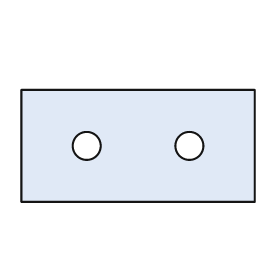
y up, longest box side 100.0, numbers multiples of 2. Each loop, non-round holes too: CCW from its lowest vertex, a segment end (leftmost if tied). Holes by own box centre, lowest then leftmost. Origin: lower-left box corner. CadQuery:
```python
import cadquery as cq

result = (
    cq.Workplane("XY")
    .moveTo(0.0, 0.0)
    .lineTo(100.0, 0.0)
    .lineTo(100.0, 48.0)
    .lineTo(0.0, 48.0)
    .close()
    .moveTo(28.0, 24.0)
    .circle(6.0)
    .moveTo(72.0, 24.0)
    .circle(6.0)
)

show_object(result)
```